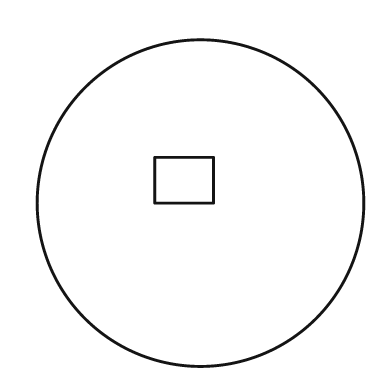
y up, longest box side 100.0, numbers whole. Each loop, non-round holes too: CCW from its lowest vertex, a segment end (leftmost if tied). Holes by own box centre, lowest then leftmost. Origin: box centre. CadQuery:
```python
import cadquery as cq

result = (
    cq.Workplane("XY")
    .moveTo(0.0, 0.0)
    .circle(50.0)
    .moveTo(-14.0, 0.0)
    .lineTo(4.0, 0.0)
    .lineTo(4.0, 14.0)
    .lineTo(-14.0, 14.0)
    .close()
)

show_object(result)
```